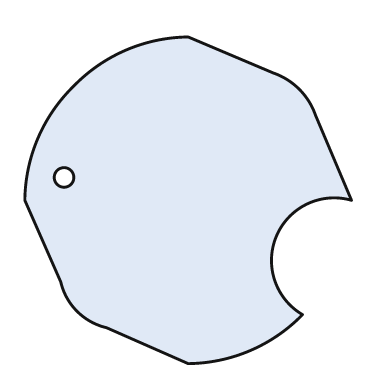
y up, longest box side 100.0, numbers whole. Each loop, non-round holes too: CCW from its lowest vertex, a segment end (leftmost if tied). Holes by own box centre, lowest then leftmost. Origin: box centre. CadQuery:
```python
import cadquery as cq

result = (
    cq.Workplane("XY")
    .moveTo(0.0, -50.0)
    .threePointArc((19.0, -46.0), (35.0, -35.0))
    .threePointArc((27.0, -11.0), (50.0, 0.0))
    .lineTo(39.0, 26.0)
    .threePointArc((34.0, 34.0), (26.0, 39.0))
    .lineTo(0.0, 50.0)
    .threePointArc((-19.0, 46.0), (-35.0, 35.0))
    .threePointArc((-46.0, 19.0), (-50.0, 0.0))
    .lineTo(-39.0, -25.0)
    .threePointArc((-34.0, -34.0), (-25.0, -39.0))
    .close()
    .moveTo(-38.0, 7.0)
    .circle(3.0)
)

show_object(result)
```